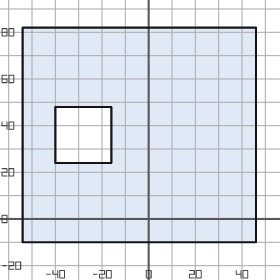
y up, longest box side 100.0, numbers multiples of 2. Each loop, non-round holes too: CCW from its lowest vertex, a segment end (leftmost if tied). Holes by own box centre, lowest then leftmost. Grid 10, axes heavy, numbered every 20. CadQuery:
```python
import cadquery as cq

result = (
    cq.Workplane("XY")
    .moveTo(-54.0, -10.0)
    .lineTo(46.0, -10.0)
    .lineTo(46.0, 82.0)
    .lineTo(-54.0, 82.0)
    .close()
    .moveTo(-40.0, 24.0)
    .lineTo(-16.0, 24.0)
    .lineTo(-16.0, 48.0)
    .lineTo(-40.0, 48.0)
    .close()
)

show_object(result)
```